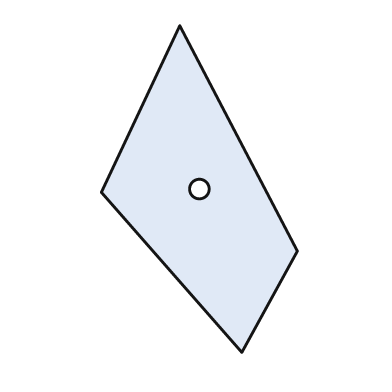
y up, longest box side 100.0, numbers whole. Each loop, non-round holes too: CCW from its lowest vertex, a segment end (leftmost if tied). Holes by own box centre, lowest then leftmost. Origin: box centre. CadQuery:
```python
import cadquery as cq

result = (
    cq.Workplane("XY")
    .moveTo(13.0, -50.0)
    .lineTo(30.0, -19.0)
    .lineTo(-6.0, 50.0)
    .lineTo(-30.0, -1.0)
    .close()
    .moveTo(0.0, 0.0)
    .circle(3.0)
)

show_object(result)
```